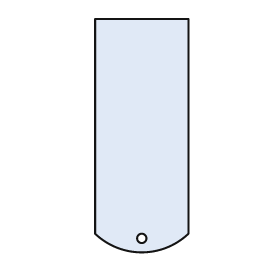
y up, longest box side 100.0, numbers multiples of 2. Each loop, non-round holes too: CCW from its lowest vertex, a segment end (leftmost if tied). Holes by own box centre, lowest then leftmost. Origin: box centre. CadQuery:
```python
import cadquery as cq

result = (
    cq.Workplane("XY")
    .moveTo(-20.0, -42.0)
    .threePointArc((0.0, -50.0), (20.0, -42.0))
    .lineTo(20.0, 50.0)
    .lineTo(-20.0, 50.0)
    .close()
    .moveTo(0.0, -44.0)
    .circle(2.0)
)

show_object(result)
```